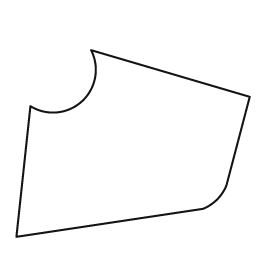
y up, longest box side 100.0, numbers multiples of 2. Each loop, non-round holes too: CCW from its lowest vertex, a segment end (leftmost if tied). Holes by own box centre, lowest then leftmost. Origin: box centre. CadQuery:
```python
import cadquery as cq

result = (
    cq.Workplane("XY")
    .moveTo(-50.0, -40.0)
    .lineTo(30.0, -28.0)
    .threePointArc((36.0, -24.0), (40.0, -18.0))
    .lineTo(50.0, 20.0)
    .lineTo(-18.0, 40.0)
    .threePointArc((-22.0, 18.0), (-44.0, 16.0))
    .close()
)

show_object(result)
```